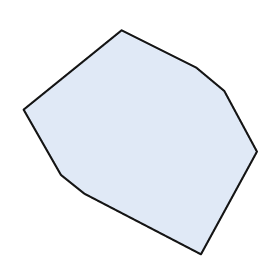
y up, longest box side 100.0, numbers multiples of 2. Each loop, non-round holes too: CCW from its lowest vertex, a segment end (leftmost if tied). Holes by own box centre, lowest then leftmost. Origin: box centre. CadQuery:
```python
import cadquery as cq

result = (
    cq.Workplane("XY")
    .moveTo(26.0, -48.0)
    .lineTo(50.0, -4.0)
    .lineTo(36.0, 22.0)
    .lineTo(24.0, 32.0)
    .lineTo(-8.0, 48.0)
    .lineTo(-50.0, 14.0)
    .lineTo(-34.0, -14.0)
    .lineTo(-24.0, -22.0)
    .close()
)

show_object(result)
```